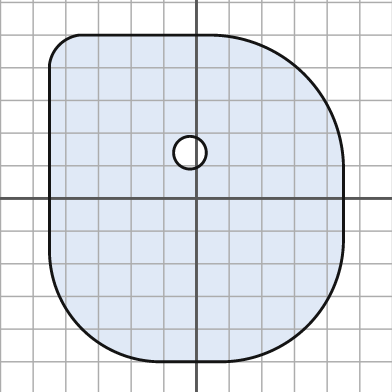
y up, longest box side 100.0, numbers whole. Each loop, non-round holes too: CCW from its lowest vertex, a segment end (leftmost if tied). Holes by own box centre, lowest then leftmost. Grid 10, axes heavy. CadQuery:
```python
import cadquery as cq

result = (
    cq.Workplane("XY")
    .moveTo(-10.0, -50.0)
    .lineTo(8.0, -50.0)
    .threePointArc((34.0, -39.0), (45.0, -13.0))
    .lineTo(45.0, 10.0)
    .threePointArc((33.0, 38.0), (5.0, 50.0))
    .lineTo(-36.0, 50.0)
    .threePointArc((-42.0, 47.0), (-45.0, 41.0))
    .lineTo(-45.0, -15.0)
    .threePointArc((-35.0, -40.0), (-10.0, -50.0))
    .close()
    .moveTo(-2.0, 14.0)
    .circle(5.0)
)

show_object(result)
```